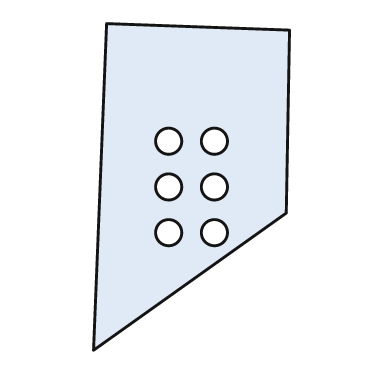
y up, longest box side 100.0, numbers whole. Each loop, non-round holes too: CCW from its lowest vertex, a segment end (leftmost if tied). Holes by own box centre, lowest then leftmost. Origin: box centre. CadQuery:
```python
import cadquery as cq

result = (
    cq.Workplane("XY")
    .moveTo(-30.0, -50.0)
    .lineTo(29.0, -8.0)
    .lineTo(30.0, 48.0)
    .lineTo(-26.0, 50.0)
    .close()
    .moveTo(-7.0, -14.0)
    .circle(4.0)
    .moveTo(7.0, -14.0)
    .circle(4.0)
    .moveTo(-7.0, 0.0)
    .circle(4.0)
    .moveTo(7.0, 0.0)
    .circle(4.0)
    .moveTo(-7.0, 14.0)
    .circle(4.0)
    .moveTo(7.0, 14.0)
    .circle(4.0)
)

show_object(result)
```